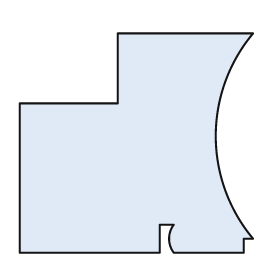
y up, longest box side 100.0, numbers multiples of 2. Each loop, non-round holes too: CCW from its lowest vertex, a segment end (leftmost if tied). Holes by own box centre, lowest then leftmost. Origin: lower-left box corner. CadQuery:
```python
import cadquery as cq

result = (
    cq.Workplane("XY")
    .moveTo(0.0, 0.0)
    .lineTo(60.0, 0.0)
    .lineTo(60.0, 12.0)
    .lineTo(66.0, 12.0)
    .threePointArc((64.0, 6.0), (66.0, 0.0))
    .lineTo(96.0, 0.0)
    .lineTo(96.0, 6.0)
    .lineTo(100.0, 6.0)
    .threePointArc((84.0, 50.0), (100.0, 94.0))
    .lineTo(42.0, 94.0)
    .lineTo(42.0, 64.0)
    .lineTo(0.0, 64.0)
    .close()
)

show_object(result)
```